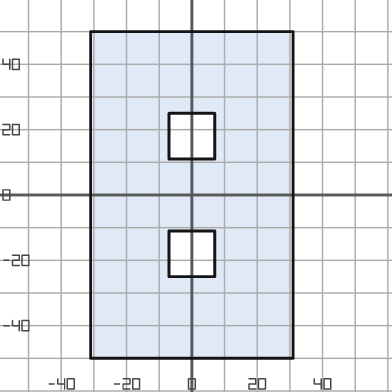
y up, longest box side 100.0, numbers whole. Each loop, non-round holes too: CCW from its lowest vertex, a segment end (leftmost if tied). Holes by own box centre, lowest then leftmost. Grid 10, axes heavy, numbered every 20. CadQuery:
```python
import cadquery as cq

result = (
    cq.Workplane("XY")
    .moveTo(-31.0, -50.0)
    .lineTo(31.0, -50.0)
    .lineTo(31.0, 50.0)
    .lineTo(-31.0, 50.0)
    .close()
    .moveTo(-7.0, -25.0)
    .lineTo(7.0, -25.0)
    .lineTo(7.0, -11.0)
    .lineTo(-7.0, -11.0)
    .close()
    .moveTo(-7.0, 11.0)
    .lineTo(7.0, 11.0)
    .lineTo(7.0, 25.0)
    .lineTo(-7.0, 25.0)
    .close()
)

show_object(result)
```